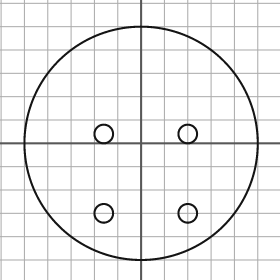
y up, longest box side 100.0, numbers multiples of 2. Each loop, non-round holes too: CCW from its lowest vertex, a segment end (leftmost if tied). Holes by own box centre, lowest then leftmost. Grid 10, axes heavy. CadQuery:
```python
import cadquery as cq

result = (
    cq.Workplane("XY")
    .moveTo(0.0, 0.0)
    .circle(50.0)
    .moveTo(-16.0, -30.0)
    .circle(4.0)
    .moveTo(20.0, -30.0)
    .circle(4.0)
    .moveTo(-16.0, 4.0)
    .circle(4.0)
    .moveTo(20.0, 4.0)
    .circle(4.0)
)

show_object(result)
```